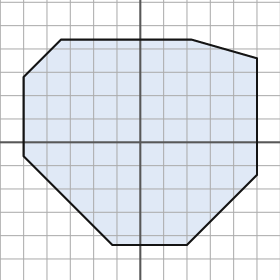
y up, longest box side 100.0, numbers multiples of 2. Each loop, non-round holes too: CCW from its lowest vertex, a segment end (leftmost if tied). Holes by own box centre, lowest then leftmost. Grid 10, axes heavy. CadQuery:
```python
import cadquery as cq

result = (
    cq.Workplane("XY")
    .moveTo(-12.0, -44.0)
    .lineTo(20.0, -44.0)
    .lineTo(50.0, -14.0)
    .lineTo(50.0, 36.0)
    .lineTo(22.0, 44.0)
    .lineTo(-34.0, 44.0)
    .lineTo(-50.0, 28.0)
    .lineTo(-50.0, -6.0)
    .close()
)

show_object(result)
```